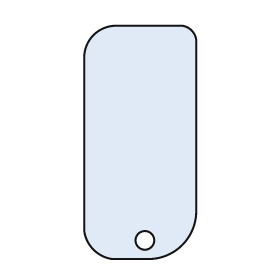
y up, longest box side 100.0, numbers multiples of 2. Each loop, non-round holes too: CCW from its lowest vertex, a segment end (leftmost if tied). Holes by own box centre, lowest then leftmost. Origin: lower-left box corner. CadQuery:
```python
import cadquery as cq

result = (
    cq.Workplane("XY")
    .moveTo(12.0, 0.0)
    .lineTo(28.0, 0.0)
    .threePointArc((42.0, 6.0), (48.0, 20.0))
    .lineTo(48.0, 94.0)
    .threePointArc((46.0, 98.0), (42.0, 100.0))
    .lineTo(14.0, 100.0)
    .threePointArc((4.0, 96.0), (0.0, 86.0))
    .lineTo(0.0, 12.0)
    .threePointArc((4.0, 4.0), (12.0, 0.0))
    .close()
    .moveTo(26.0, 8.0)
    .circle(4.0)
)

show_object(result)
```